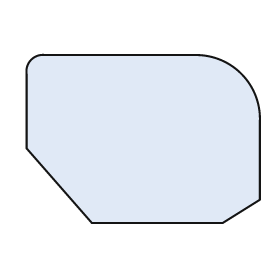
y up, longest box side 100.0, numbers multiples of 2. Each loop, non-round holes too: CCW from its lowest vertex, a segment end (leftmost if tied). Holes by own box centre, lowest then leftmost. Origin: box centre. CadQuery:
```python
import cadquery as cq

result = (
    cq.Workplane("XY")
    .moveTo(-22.0, -36.0)
    .lineTo(34.0, -36.0)
    .lineTo(50.0, -26.0)
    .lineTo(50.0, 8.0)
    .threePointArc((42.0, 28.0), (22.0, 36.0))
    .lineTo(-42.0, 36.0)
    .threePointArc((-48.0, 34.0), (-50.0, 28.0))
    .lineTo(-50.0, -4.0)
    .close()
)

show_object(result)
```